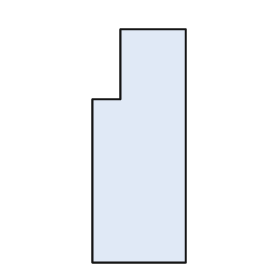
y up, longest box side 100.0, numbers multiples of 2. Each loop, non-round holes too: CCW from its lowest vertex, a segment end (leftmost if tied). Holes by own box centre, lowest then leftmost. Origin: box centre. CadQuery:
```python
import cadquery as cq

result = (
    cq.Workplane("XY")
    .moveTo(-20.0, -50.0)
    .lineTo(20.0, -50.0)
    .lineTo(20.0, 50.0)
    .lineTo(-8.0, 50.0)
    .lineTo(-8.0, 20.0)
    .lineTo(-20.0, 20.0)
    .close()
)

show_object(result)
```